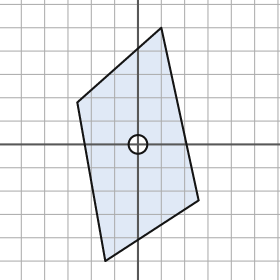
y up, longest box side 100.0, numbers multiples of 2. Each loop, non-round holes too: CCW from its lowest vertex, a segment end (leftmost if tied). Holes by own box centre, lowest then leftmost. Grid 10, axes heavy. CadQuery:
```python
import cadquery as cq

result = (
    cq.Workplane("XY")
    .moveTo(-14.0, -50.0)
    .lineTo(26.0, -24.0)
    .lineTo(10.0, 50.0)
    .lineTo(-26.0, 18.0)
    .close()
    .moveTo(0.0, 0.0)
    .circle(4.0)
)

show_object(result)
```